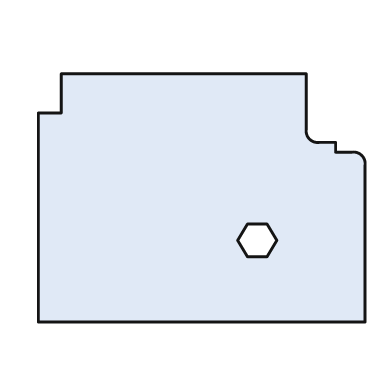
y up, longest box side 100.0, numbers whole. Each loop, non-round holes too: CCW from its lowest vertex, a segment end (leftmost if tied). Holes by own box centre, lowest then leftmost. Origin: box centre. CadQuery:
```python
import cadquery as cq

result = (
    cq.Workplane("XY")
    .moveTo(-50.0, -38.0)
    .lineTo(50.0, -38.0)
    .lineTo(50.0, 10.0)
    .threePointArc((49.0, 13.0), (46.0, 14.0))
    .lineTo(41.0, 14.0)
    .lineTo(41.0, 17.0)
    .lineTo(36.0, 17.0)
    .threePointArc((33.0, 18.0), (32.0, 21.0))
    .lineTo(32.0, 38.0)
    .lineTo(-43.0, 38.0)
    .lineTo(-43.0, 26.0)
    .lineTo(-50.0, 26.0)
    .close()
    .moveTo(14.0, -18.0)
    .lineTo(20.0, -18.0)
    .lineTo(23.0, -13.0)
    .lineTo(20.0, -8.0)
    .lineTo(14.0, -8.0)
    .lineTo(11.0, -13.0)
    .close()
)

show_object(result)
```